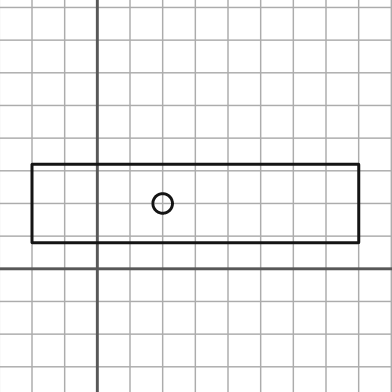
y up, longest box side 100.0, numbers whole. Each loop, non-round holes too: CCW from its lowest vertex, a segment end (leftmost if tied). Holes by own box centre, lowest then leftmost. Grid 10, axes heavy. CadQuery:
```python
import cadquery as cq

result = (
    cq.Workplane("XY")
    .moveTo(-20.0, 8.0)
    .lineTo(80.0, 8.0)
    .lineTo(80.0, 32.0)
    .lineTo(-20.0, 32.0)
    .close()
    .moveTo(20.0, 20.0)
    .circle(3.0)
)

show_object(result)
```